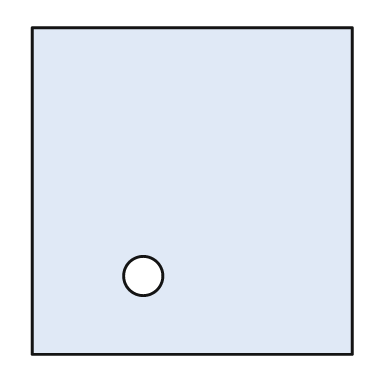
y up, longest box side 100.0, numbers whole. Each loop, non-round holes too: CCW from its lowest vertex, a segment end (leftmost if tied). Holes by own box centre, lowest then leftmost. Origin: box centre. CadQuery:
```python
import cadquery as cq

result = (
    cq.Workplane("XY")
    .moveTo(-49.0, -50.0)
    .lineTo(49.0, -50.0)
    .lineTo(49.0, 50.0)
    .lineTo(-49.0, 50.0)
    .close()
    .moveTo(-15.0, -26.0)
    .circle(6.0)
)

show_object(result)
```